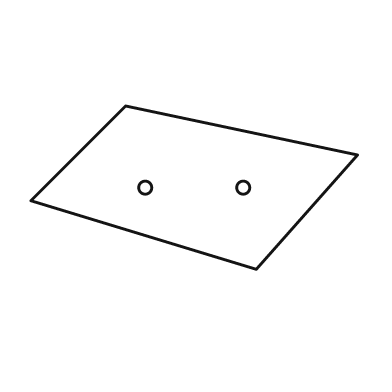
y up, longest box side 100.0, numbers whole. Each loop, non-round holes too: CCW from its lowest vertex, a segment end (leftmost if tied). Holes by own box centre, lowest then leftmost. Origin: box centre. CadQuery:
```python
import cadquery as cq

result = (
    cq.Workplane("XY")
    .moveTo(19.0, -25.0)
    .lineTo(50.0, 10.0)
    .lineTo(-21.0, 25.0)
    .lineTo(-50.0, -4.0)
    .close()
    .moveTo(-15.0, 0.0)
    .circle(2.0)
    .moveTo(15.0, 0.0)
    .circle(2.0)
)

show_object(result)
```